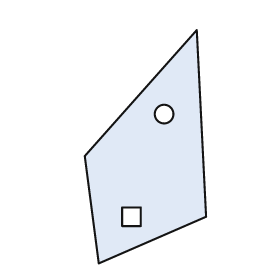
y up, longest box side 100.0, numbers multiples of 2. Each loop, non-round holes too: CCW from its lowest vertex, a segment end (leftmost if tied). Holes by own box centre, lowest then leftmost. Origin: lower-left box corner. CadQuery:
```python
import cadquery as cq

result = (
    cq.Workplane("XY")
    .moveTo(6.0, 0.0)
    .lineTo(52.0, 20.0)
    .lineTo(48.0, 100.0)
    .lineTo(0.0, 46.0)
    .close()
    .moveTo(16.0, 16.0)
    .lineTo(24.0, 16.0)
    .lineTo(24.0, 24.0)
    .lineTo(16.0, 24.0)
    .close()
    .moveTo(34.0, 64.0)
    .circle(4.0)
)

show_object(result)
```